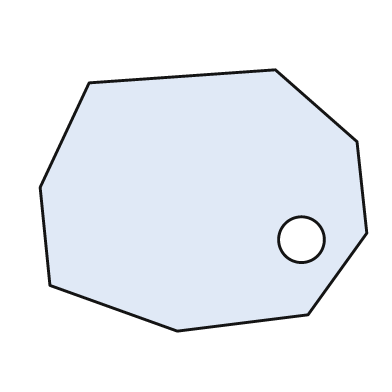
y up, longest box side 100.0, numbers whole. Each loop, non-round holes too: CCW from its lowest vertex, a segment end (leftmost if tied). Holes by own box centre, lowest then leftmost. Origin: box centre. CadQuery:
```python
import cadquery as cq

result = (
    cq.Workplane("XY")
    .moveTo(-8.0, -40.0)
    .lineTo(32.0, -35.0)
    .lineTo(50.0, -10.0)
    .lineTo(47.0, 18.0)
    .lineTo(22.0, 40.0)
    .lineTo(-35.0, 36.0)
    .lineTo(-50.0, 4.0)
    .lineTo(-47.0, -26.0)
    .close()
    .moveTo(30.0, -12.0)
    .circle(7.0)
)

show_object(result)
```